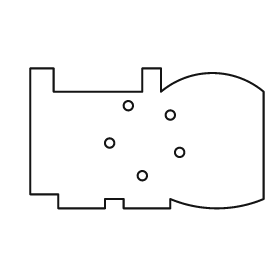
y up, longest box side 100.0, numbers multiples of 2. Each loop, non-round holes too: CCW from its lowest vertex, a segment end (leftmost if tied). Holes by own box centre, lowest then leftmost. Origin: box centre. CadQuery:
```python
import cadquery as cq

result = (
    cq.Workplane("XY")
    .moveTo(-38.0, -30.0)
    .lineTo(-18.0, -30.0)
    .lineTo(-18.0, -26.0)
    .lineTo(-10.0, -26.0)
    .lineTo(-10.0, -30.0)
    .lineTo(10.0, -30.0)
    .lineTo(10.0, -26.0)
    .threePointArc((30.0, -30.0), (50.0, -26.0))
    .lineTo(50.0, 20.0)
    .threePointArc((28.0, 28.0), (6.0, 20.0))
    .lineTo(6.0, 30.0)
    .lineTo(-2.0, 30.0)
    .lineTo(-2.0, 20.0)
    .lineTo(-40.0, 20.0)
    .lineTo(-40.0, 30.0)
    .lineTo(-50.0, 30.0)
    .lineTo(-50.0, -24.0)
    .lineTo(-38.0, -24.0)
    .close()
    .moveTo(-2.0, -16.0)
    .circle(2.0)
    .moveTo(14.0, -6.0)
    .circle(2.0)
    .moveTo(-16.0, -2.0)
    .circle(2.0)
    .moveTo(10.0, 10.0)
    .circle(2.0)
    .moveTo(-8.0, 14.0)
    .circle(2.0)
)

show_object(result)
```